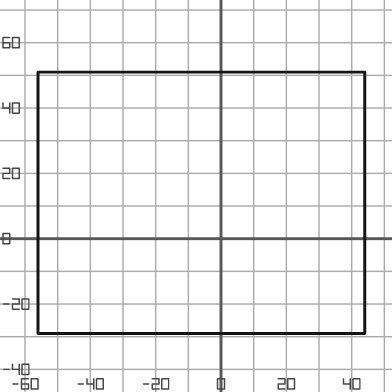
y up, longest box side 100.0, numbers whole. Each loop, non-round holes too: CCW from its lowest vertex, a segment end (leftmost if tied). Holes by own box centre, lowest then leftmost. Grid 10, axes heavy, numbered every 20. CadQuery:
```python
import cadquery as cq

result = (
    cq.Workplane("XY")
    .moveTo(-56.0, -29.0)
    .lineTo(44.0, -29.0)
    .lineTo(44.0, 51.0)
    .lineTo(-56.0, 51.0)
    .close()
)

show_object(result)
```